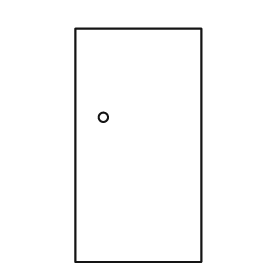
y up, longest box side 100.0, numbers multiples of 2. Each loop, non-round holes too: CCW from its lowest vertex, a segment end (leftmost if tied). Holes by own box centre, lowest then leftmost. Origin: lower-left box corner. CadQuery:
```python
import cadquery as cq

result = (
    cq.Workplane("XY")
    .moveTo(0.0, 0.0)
    .lineTo(54.0, 0.0)
    .lineTo(54.0, 100.0)
    .lineTo(0.0, 100.0)
    .close()
    .moveTo(12.0, 62.0)
    .circle(2.0)
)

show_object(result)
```